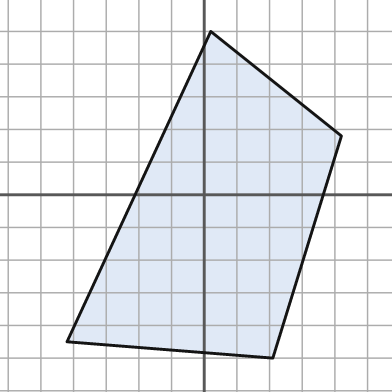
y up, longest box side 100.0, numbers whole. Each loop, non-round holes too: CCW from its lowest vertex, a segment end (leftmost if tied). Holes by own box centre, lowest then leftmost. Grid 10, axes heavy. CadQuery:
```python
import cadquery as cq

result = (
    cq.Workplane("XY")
    .moveTo(21.0, -50.0)
    .lineTo(42.0, 18.0)
    .lineTo(2.0, 50.0)
    .lineTo(-42.0, -45.0)
    .close()
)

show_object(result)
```